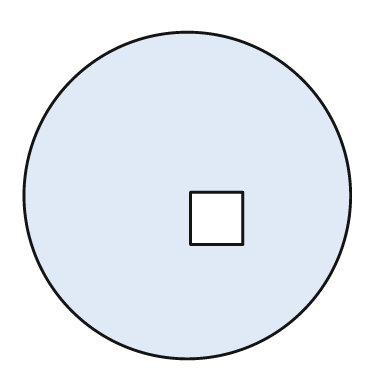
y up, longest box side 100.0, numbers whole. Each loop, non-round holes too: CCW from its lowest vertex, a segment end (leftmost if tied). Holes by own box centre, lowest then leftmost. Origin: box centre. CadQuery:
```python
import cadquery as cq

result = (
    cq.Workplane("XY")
    .moveTo(0.0, 0.0)
    .circle(50.0)
    .moveTo(1.0, -15.0)
    .lineTo(17.0, -15.0)
    .lineTo(17.0, 1.0)
    .lineTo(1.0, 1.0)
    .close()
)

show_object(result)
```